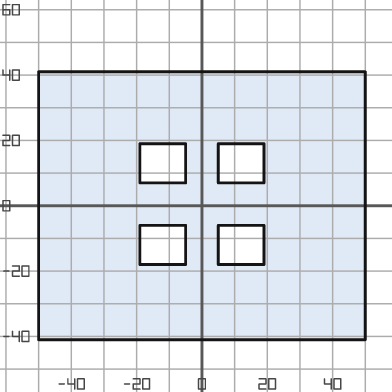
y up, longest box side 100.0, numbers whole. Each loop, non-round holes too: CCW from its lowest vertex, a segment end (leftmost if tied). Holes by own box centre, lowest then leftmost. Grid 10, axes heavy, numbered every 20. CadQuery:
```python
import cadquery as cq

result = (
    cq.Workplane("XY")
    .moveTo(-50.0, -41.0)
    .lineTo(50.0, -41.0)
    .lineTo(50.0, 41.0)
    .lineTo(-50.0, 41.0)
    .close()
    .moveTo(-19.0, -18.0)
    .lineTo(-5.0, -18.0)
    .lineTo(-5.0, -6.0)
    .lineTo(-19.0, -6.0)
    .close()
    .moveTo(5.0, -18.0)
    .lineTo(19.0, -18.0)
    .lineTo(19.0, -6.0)
    .lineTo(5.0, -6.0)
    .close()
    .moveTo(-19.0, 7.0)
    .lineTo(-5.0, 7.0)
    .lineTo(-5.0, 19.0)
    .lineTo(-19.0, 19.0)
    .close()
    .moveTo(5.0, 7.0)
    .lineTo(19.0, 7.0)
    .lineTo(19.0, 19.0)
    .lineTo(5.0, 19.0)
    .close()
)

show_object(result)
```